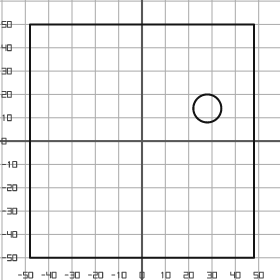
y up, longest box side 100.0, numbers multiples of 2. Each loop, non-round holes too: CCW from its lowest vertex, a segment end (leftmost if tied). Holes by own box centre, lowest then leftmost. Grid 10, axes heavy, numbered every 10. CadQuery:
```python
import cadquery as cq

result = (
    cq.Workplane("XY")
    .moveTo(-48.0, -50.0)
    .lineTo(48.0, -50.0)
    .lineTo(48.0, 50.0)
    .lineTo(-48.0, 50.0)
    .close()
    .moveTo(28.0, 14.0)
    .circle(6.0)
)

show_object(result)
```